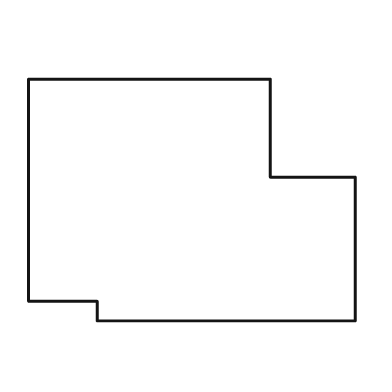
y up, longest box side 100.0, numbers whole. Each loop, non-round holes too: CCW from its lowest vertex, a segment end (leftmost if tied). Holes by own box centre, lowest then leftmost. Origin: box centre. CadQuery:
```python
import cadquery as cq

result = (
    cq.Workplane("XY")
    .moveTo(-29.0, -37.0)
    .lineTo(50.0, -37.0)
    .lineTo(50.0, 7.0)
    .lineTo(24.0, 7.0)
    .lineTo(24.0, 37.0)
    .lineTo(-50.0, 37.0)
    .lineTo(-50.0, -31.0)
    .lineTo(-29.0, -31.0)
    .close()
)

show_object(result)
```